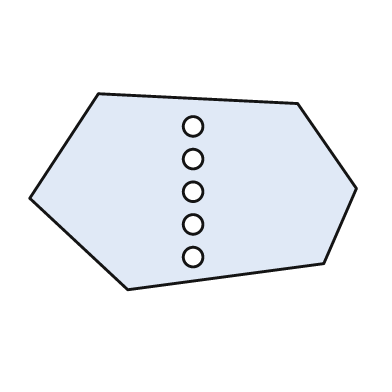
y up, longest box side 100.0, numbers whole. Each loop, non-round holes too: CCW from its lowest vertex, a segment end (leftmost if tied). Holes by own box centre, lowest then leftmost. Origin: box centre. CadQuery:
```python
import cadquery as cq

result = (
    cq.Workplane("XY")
    .moveTo(-20.0, -30.0)
    .lineTo(40.0, -22.0)
    .lineTo(50.0, 1.0)
    .lineTo(32.0, 27.0)
    .lineTo(-29.0, 30.0)
    .lineTo(-50.0, -2.0)
    .close()
    .moveTo(0.0, -20.0)
    .circle(3.0)
    .moveTo(0.0, -10.0)
    .circle(3.0)
    .moveTo(0.0, 0.0)
    .circle(3.0)
    .moveTo(0.0, 10.0)
    .circle(3.0)
    .moveTo(0.0, 20.0)
    .circle(3.0)
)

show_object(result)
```